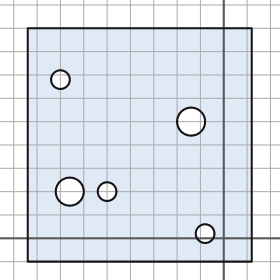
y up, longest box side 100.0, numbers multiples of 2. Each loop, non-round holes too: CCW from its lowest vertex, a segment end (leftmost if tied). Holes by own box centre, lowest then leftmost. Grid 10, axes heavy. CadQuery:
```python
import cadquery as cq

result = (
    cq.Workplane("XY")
    .moveTo(-84.0, -10.0)
    .lineTo(12.0, -10.0)
    .lineTo(12.0, 90.0)
    .lineTo(-84.0, 90.0)
    .close()
    .moveTo(-8.0, 2.0)
    .circle(4.0)
    .moveTo(-66.0, 20.0)
    .circle(6.0)
    .moveTo(-50.0, 20.0)
    .circle(4.0)
    .moveTo(-14.0, 50.0)
    .circle(6.0)
    .moveTo(-70.0, 68.0)
    .circle(4.0)
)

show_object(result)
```